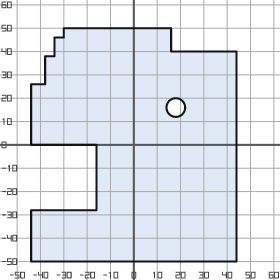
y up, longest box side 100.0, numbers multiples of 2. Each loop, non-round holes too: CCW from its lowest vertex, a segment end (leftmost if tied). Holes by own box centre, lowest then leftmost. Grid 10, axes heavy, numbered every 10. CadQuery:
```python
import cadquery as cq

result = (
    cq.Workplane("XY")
    .moveTo(-44.0, -50.0)
    .lineTo(44.0, -50.0)
    .lineTo(44.0, 40.0)
    .lineTo(16.0, 40.0)
    .lineTo(16.0, 50.0)
    .lineTo(-30.0, 50.0)
    .lineTo(-30.0, 46.0)
    .lineTo(-34.0, 46.0)
    .lineTo(-34.0, 38.0)
    .lineTo(-38.0, 38.0)
    .lineTo(-38.0, 26.0)
    .lineTo(-44.0, 26.0)
    .lineTo(-44.0, 0.0)
    .lineTo(-16.0, 0.0)
    .lineTo(-16.0, -28.0)
    .lineTo(-44.0, -28.0)
    .close()
    .moveTo(18.0, 16.0)
    .circle(4.0)
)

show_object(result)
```